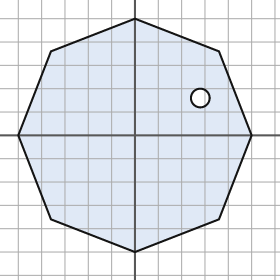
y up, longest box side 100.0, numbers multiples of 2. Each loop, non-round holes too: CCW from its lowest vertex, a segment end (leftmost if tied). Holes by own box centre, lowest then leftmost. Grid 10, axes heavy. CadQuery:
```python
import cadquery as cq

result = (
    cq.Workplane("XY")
    .moveTo(0.0, -50.0)
    .lineTo(36.0, -36.0)
    .lineTo(50.0, 0.0)
    .lineTo(36.0, 36.0)
    .lineTo(0.0, 50.0)
    .lineTo(-36.0, 36.0)
    .lineTo(-50.0, 0.0)
    .lineTo(-36.0, -36.0)
    .close()
    .moveTo(28.0, 16.0)
    .circle(4.0)
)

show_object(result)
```